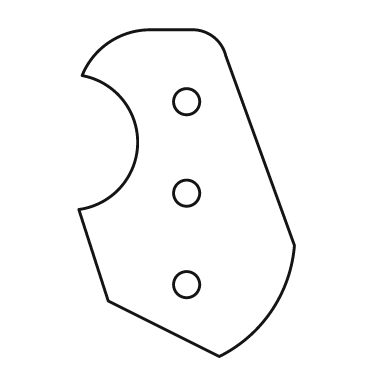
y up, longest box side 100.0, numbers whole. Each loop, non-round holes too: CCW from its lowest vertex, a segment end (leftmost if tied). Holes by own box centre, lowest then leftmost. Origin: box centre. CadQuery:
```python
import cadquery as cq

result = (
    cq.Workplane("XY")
    .moveTo(10.0, -50.0)
    .threePointArc((26.0, -36.0), (33.0, -16.0))
    .lineTo(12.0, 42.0)
    .threePointArc((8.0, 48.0), (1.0, 50.0))
    .lineTo(-12.0, 50.0)
    .threePointArc((-24.0, 46.0), (-32.0, 36.0))
    .threePointArc((-15.0, 15.0), (-33.0, -5.0))
    .lineTo(-24.0, -33.0)
    .close()
    .moveTo(0.0, -28.0)
    .circle(4.0)
    .moveTo(0.0, 0.0)
    .circle(4.0)
    .moveTo(0.0, 28.0)
    .circle(4.0)
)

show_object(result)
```